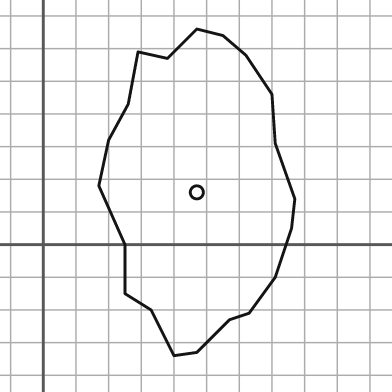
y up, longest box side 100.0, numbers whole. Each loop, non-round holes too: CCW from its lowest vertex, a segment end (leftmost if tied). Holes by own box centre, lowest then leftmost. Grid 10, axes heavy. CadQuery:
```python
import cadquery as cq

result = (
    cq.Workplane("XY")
    .moveTo(40.0, -34.0)
    .lineTo(47.0, -33.0)
    .lineTo(57.0, -23.0)
    .lineTo(63.0, -21.0)
    .lineTo(71.0, -10.0)
    .lineTo(76.0, 5.0)
    .lineTo(77.0, 14.0)
    .lineTo(71.0, 31.0)
    .lineTo(70.0, 46.0)
    .lineTo(62.0, 58.0)
    .lineTo(55.0, 64.0)
    .lineTo(47.0, 66.0)
    .lineTo(38.0, 57.0)
    .lineTo(29.0, 59.0)
    .lineTo(26.0, 43.0)
    .lineTo(20.0, 32.0)
    .lineTo(17.0, 18.0)
    .lineTo(25.0, 0.0)
    .lineTo(25.0, -15.0)
    .lineTo(33.0, -20.0)
    .close()
    .moveTo(47.0, 16.0)
    .circle(2.0)
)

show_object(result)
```